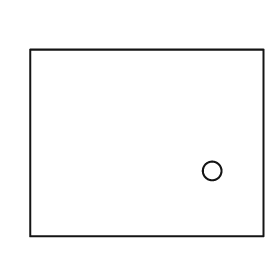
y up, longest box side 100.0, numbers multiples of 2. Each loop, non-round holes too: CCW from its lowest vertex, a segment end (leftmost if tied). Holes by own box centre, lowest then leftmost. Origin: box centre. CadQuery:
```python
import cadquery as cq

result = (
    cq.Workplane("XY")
    .moveTo(-50.0, -40.0)
    .lineTo(50.0, -40.0)
    .lineTo(50.0, 40.0)
    .lineTo(-50.0, 40.0)
    .close()
    .moveTo(28.0, -12.0)
    .circle(4.0)
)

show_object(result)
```